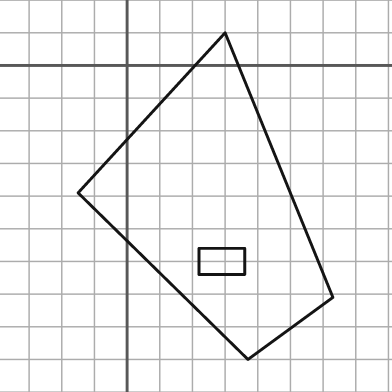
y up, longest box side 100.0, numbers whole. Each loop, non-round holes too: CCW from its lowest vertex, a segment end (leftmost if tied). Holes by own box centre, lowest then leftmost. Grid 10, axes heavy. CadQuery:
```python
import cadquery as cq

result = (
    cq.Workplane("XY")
    .moveTo(37.0, -90.0)
    .lineTo(63.0, -71.0)
    .lineTo(30.0, 10.0)
    .lineTo(-15.0, -39.0)
    .close()
    .moveTo(22.0, -64.0)
    .lineTo(36.0, -64.0)
    .lineTo(36.0, -56.0)
    .lineTo(22.0, -56.0)
    .close()
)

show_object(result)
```